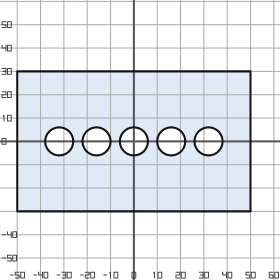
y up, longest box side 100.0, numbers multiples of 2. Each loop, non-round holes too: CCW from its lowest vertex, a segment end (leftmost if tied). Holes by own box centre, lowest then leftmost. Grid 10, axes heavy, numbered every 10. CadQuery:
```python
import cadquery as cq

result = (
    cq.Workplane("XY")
    .moveTo(-50.0, -30.0)
    .lineTo(50.0, -30.0)
    .lineTo(50.0, 30.0)
    .lineTo(-50.0, 30.0)
    .close()
    .moveTo(-32.0, 0.0)
    .circle(6.0)
    .moveTo(-16.0, 0.0)
    .circle(6.0)
    .moveTo(0.0, 0.0)
    .circle(6.0)
    .moveTo(16.0, 0.0)
    .circle(6.0)
    .moveTo(32.0, 0.0)
    .circle(6.0)
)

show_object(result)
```